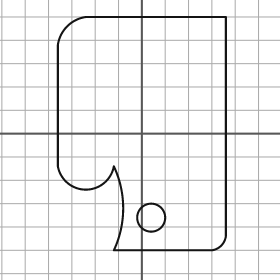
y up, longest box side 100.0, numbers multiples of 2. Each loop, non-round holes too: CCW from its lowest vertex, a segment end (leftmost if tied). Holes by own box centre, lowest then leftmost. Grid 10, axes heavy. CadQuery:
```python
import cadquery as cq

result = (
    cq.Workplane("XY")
    .moveTo(-12.0, -50.0)
    .lineTo(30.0, -50.0)
    .threePointArc((34.0, -48.0), (36.0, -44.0))
    .lineTo(36.0, 50.0)
    .lineTo(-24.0, 50.0)
    .threePointArc((-32.0, 46.0), (-36.0, 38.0))
    .lineTo(-36.0, -14.0)
    .threePointArc((-24.0, -24.0), (-12.0, -14.0))
    .threePointArc((-8.0, -32.0), (-12.0, -50.0))
    .close()
    .moveTo(4.0, -36.0)
    .circle(6.0)
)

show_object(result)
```